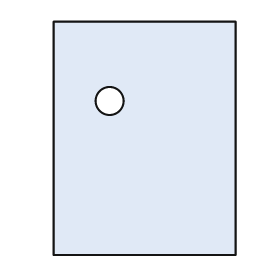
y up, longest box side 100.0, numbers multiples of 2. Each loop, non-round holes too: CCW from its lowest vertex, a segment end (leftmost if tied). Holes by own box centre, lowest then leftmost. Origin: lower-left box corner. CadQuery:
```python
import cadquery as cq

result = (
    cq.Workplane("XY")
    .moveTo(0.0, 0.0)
    .lineTo(78.0, 0.0)
    .lineTo(78.0, 100.0)
    .lineTo(0.0, 100.0)
    .close()
    .moveTo(24.0, 66.0)
    .circle(6.0)
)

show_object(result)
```